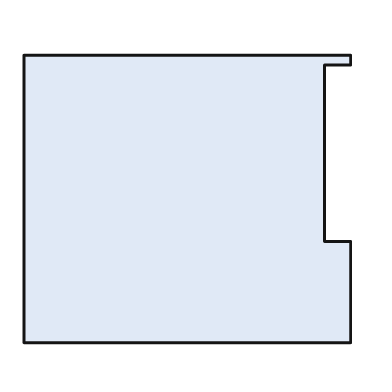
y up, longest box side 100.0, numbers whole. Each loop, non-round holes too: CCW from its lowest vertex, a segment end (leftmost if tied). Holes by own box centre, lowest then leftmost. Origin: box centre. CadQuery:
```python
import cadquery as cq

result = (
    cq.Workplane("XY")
    .moveTo(-50.0, -44.0)
    .lineTo(50.0, -44.0)
    .lineTo(50.0, -13.0)
    .lineTo(42.0, -13.0)
    .lineTo(42.0, 41.0)
    .lineTo(50.0, 41.0)
    .lineTo(50.0, 44.0)
    .lineTo(-50.0, 44.0)
    .close()
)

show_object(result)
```